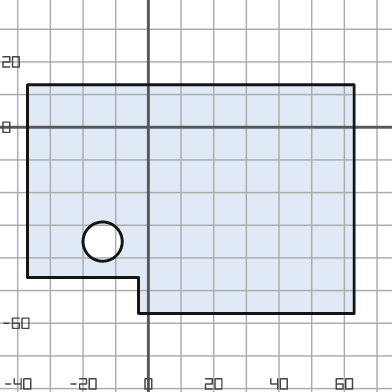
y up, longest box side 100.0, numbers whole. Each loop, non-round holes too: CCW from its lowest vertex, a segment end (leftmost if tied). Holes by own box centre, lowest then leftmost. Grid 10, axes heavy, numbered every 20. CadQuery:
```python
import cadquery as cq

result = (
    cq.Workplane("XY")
    .moveTo(-3.0, -57.0)
    .lineTo(63.0, -57.0)
    .lineTo(63.0, 13.0)
    .lineTo(-37.0, 13.0)
    .lineTo(-37.0, -46.0)
    .lineTo(-3.0, -46.0)
    .close()
    .moveTo(-14.0, -35.0)
    .circle(6.0)
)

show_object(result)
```